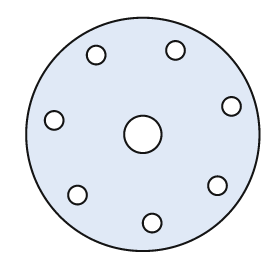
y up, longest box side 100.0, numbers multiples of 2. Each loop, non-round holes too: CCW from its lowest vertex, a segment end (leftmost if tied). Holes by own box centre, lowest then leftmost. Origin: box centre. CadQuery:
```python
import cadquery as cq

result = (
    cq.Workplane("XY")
    .moveTo(0.0, 0.0)
    .circle(50.0)
    .moveTo(4.0, -38.0)
    .circle(4.0)
    .moveTo(-28.0, -26.0)
    .circle(4.0)
    .moveTo(32.0, -22.0)
    .circle(4.0)
    .moveTo(0.0, 0.0)
    .circle(8.0)
    .moveTo(-38.0, 6.0)
    .circle(4.0)
    .moveTo(38.0, 12.0)
    .circle(4.0)
    .moveTo(-20.0, 34.0)
    .circle(4.0)
    .moveTo(14.0, 36.0)
    .circle(4.0)
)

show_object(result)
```